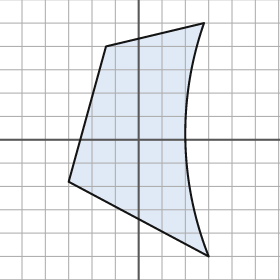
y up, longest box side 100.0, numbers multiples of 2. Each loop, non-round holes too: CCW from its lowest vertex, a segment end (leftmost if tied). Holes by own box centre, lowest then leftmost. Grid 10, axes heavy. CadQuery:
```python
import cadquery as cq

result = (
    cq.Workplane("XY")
    .moveTo(30.0, -50.0)
    .threePointArc((20.0, 0.0), (28.0, 50.0))
    .lineTo(-14.0, 40.0)
    .lineTo(-30.0, -18.0)
    .close()
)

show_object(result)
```